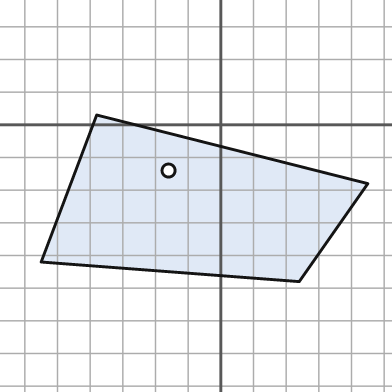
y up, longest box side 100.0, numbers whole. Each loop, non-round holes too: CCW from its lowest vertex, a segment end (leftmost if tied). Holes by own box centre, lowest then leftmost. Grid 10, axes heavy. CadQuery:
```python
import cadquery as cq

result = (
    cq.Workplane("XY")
    .moveTo(24.0, -48.0)
    .lineTo(45.0, -18.0)
    .lineTo(-38.0, 3.0)
    .lineTo(-55.0, -42.0)
    .close()
    .moveTo(-16.0, -14.0)
    .circle(2.0)
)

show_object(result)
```